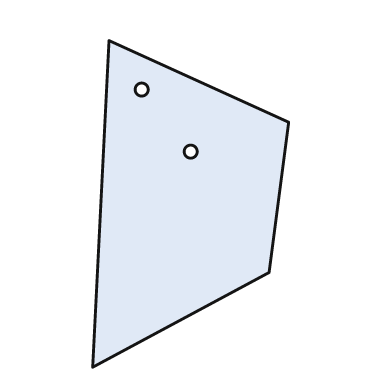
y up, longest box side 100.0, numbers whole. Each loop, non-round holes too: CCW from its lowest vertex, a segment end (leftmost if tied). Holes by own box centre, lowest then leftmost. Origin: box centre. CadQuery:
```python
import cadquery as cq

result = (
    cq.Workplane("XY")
    .moveTo(-30.0, -50.0)
    .lineTo(24.0, -21.0)
    .lineTo(30.0, 25.0)
    .lineTo(-25.0, 50.0)
    .close()
    .moveTo(0.0, 16.0)
    .circle(2.0)
    .moveTo(-15.0, 35.0)
    .circle(2.0)
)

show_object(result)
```